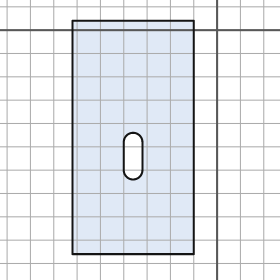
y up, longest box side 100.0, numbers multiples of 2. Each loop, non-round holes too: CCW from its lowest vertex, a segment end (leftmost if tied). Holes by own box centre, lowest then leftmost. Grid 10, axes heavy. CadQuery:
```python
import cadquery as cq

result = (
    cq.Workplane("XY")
    .moveTo(-62.0, -96.0)
    .lineTo(-10.0, -96.0)
    .lineTo(-10.0, 4.0)
    .lineTo(-62.0, 4.0)
    .close()
    .moveTo(-40.0, -60.0)
    .threePointArc((-36.0, -64.0), (-32.0, -60.0))
    .lineTo(-32.0, -48.0)
    .threePointArc((-36.0, -44.0), (-40.0, -48.0))
    .close()
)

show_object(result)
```